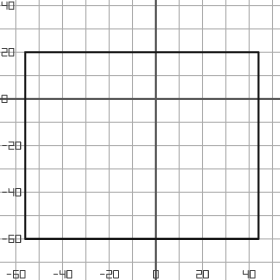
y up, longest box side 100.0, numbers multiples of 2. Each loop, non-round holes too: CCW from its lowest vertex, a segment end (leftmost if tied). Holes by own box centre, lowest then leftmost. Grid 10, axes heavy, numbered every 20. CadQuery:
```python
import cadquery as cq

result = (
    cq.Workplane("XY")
    .moveTo(-56.0, -60.0)
    .lineTo(44.0, -60.0)
    .lineTo(44.0, 20.0)
    .lineTo(-56.0, 20.0)
    .close()
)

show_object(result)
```